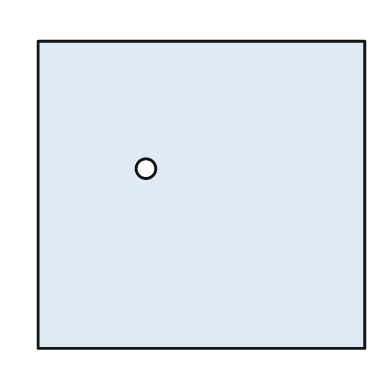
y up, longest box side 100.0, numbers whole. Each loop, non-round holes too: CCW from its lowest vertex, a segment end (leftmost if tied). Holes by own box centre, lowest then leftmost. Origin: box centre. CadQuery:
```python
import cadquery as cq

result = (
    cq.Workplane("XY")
    .moveTo(-50.0, -47.0)
    .lineTo(50.0, -47.0)
    .lineTo(50.0, 47.0)
    .lineTo(-50.0, 47.0)
    .close()
    .moveTo(-17.0, 8.0)
    .circle(3.0)
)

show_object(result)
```